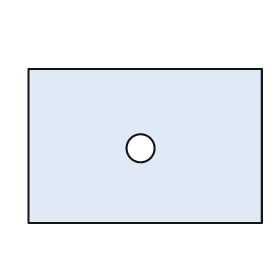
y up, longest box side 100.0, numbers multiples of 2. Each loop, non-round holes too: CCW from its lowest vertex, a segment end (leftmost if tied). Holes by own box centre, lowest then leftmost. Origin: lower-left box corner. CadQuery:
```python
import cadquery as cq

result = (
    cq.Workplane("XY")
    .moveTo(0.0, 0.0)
    .lineTo(100.0, 0.0)
    .lineTo(100.0, 66.0)
    .lineTo(0.0, 66.0)
    .close()
    .moveTo(48.0, 32.0)
    .circle(6.0)
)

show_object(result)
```